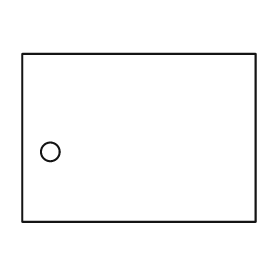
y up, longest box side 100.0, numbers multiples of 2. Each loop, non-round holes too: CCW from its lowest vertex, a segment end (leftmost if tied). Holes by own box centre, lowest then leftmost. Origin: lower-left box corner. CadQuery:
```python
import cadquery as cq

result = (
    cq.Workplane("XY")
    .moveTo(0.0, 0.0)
    .lineTo(100.0, 0.0)
    .lineTo(100.0, 72.0)
    .lineTo(0.0, 72.0)
    .close()
    .moveTo(12.0, 30.0)
    .circle(4.0)
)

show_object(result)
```